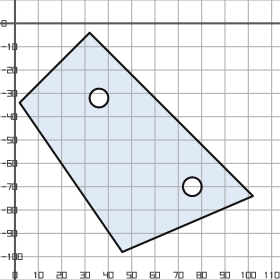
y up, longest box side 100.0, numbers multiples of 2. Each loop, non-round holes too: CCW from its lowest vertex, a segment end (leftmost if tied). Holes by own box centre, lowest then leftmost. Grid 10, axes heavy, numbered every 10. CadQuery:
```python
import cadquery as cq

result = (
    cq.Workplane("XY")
    .moveTo(46.0, -98.0)
    .lineTo(102.0, -74.0)
    .lineTo(32.0, -4.0)
    .lineTo(2.0, -34.0)
    .close()
    .moveTo(76.0, -70.0)
    .circle(4.0)
    .moveTo(36.0, -32.0)
    .circle(4.0)
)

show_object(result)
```